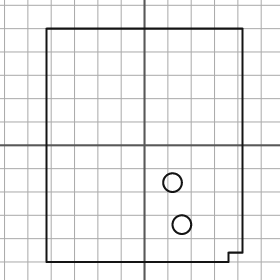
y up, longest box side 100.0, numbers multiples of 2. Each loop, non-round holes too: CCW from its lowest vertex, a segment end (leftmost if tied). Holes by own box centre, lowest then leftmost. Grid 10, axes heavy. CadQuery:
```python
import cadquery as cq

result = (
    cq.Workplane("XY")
    .moveTo(-42.0, -50.0)
    .lineTo(36.0, -50.0)
    .lineTo(36.0, -46.0)
    .lineTo(42.0, -46.0)
    .lineTo(42.0, 50.0)
    .lineTo(-42.0, 50.0)
    .close()
    .moveTo(16.0, -34.0)
    .circle(4.0)
    .moveTo(12.0, -16.0)
    .circle(4.0)
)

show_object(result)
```